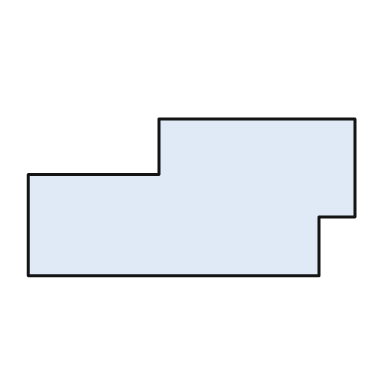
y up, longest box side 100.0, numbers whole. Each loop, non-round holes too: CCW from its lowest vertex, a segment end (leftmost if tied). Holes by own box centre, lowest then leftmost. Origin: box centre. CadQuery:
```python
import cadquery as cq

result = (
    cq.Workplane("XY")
    .moveTo(-50.0, -24.0)
    .lineTo(39.0, -24.0)
    .lineTo(39.0, -6.0)
    .lineTo(50.0, -6.0)
    .lineTo(50.0, 24.0)
    .lineTo(-10.0, 24.0)
    .lineTo(-10.0, 7.0)
    .lineTo(-50.0, 7.0)
    .close()
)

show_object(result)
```